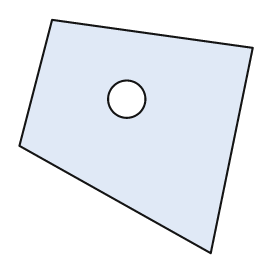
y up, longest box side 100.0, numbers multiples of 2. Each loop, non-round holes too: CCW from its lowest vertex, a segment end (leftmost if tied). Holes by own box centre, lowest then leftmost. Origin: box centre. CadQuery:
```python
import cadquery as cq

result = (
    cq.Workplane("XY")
    .moveTo(32.0, -50.0)
    .lineTo(50.0, 38.0)
    .lineTo(-36.0, 50.0)
    .lineTo(-50.0, -4.0)
    .close()
    .moveTo(-4.0, 16.0)
    .circle(8.0)
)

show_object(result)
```